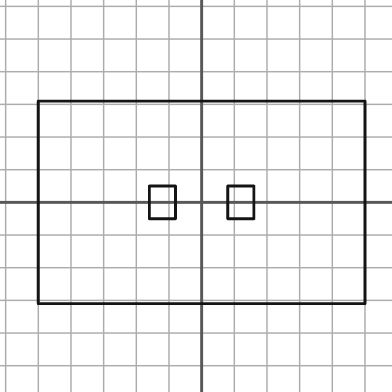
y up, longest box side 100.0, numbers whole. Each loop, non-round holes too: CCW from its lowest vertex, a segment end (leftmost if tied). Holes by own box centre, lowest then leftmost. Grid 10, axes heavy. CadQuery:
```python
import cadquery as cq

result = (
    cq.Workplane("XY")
    .moveTo(-50.0, -31.0)
    .lineTo(50.0, -31.0)
    .lineTo(50.0, 31.0)
    .lineTo(-50.0, 31.0)
    .close()
    .moveTo(-16.0, -5.0)
    .lineTo(-8.0, -5.0)
    .lineTo(-8.0, 5.0)
    .lineTo(-16.0, 5.0)
    .close()
    .moveTo(8.0, -5.0)
    .lineTo(16.0, -5.0)
    .lineTo(16.0, 5.0)
    .lineTo(8.0, 5.0)
    .close()
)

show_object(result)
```